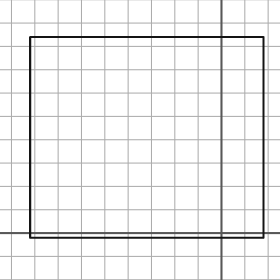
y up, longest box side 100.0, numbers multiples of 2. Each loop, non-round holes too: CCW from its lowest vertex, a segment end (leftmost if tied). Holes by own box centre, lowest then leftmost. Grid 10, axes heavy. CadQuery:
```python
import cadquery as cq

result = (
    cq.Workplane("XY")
    .moveTo(-82.0, -2.0)
    .lineTo(18.0, -2.0)
    .lineTo(18.0, 84.0)
    .lineTo(-82.0, 84.0)
    .close()
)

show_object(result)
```